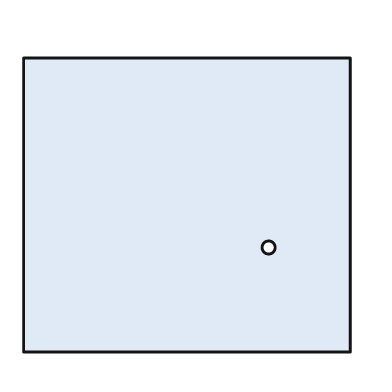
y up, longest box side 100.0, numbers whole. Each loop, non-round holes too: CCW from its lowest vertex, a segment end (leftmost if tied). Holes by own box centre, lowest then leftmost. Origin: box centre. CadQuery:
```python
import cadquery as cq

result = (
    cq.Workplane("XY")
    .moveTo(-50.0, -45.0)
    .lineTo(50.0, -45.0)
    .lineTo(50.0, 45.0)
    .lineTo(-50.0, 45.0)
    .close()
    .moveTo(25.0, -13.0)
    .circle(2.0)
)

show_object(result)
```